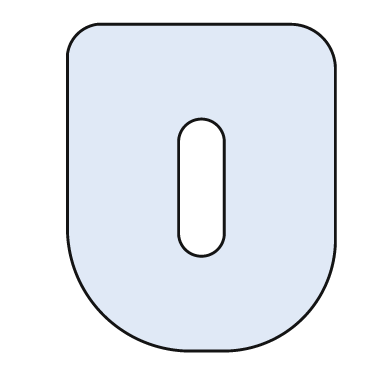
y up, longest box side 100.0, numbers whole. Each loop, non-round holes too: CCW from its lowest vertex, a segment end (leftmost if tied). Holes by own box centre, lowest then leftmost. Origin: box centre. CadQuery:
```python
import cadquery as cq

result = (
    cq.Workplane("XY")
    .moveTo(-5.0, -50.0)
    .lineTo(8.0, -50.0)
    .threePointArc((31.0, -40.0), (41.0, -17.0))
    .lineTo(41.0, 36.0)
    .threePointArc((37.0, 46.0), (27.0, 50.0))
    .lineTo(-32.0, 50.0)
    .threePointArc((-38.0, 47.0), (-41.0, 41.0))
    .lineTo(-41.0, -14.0)
    .threePointArc((-30.0, -39.0), (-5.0, -50.0))
    .close()
    .moveTo(-7.0, -14.0)
    .threePointArc((0.0, -21.0), (7.0, -14.0))
    .lineTo(7.0, 14.0)
    .threePointArc((0.0, 21.0), (-7.0, 14.0))
    .close()
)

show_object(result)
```